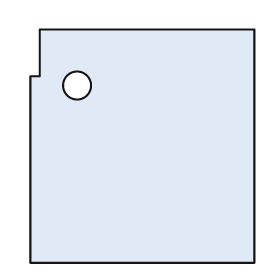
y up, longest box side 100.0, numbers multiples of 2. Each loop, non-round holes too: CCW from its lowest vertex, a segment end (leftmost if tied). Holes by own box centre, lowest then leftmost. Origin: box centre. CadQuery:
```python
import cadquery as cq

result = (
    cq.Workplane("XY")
    .moveTo(-48.0, -50.0)
    .lineTo(48.0, -50.0)
    .lineTo(48.0, 50.0)
    .lineTo(-44.0, 50.0)
    .lineTo(-44.0, 30.0)
    .lineTo(-48.0, 30.0)
    .close()
    .moveTo(-28.0, 26.0)
    .circle(6.0)
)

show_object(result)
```